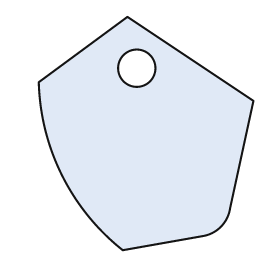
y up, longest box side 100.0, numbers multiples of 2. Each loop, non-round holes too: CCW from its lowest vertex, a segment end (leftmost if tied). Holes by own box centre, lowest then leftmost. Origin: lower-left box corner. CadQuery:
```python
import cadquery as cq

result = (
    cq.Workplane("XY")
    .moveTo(36.0, 0.0)
    .lineTo(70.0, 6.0)
    .threePointArc((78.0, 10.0), (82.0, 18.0))
    .lineTo(92.0, 64.0)
    .lineTo(38.0, 100.0)
    .lineTo(0.0, 72.0)
    .threePointArc((10.0, 32.0), (36.0, 0.0))
    .close()
    .moveTo(42.0, 78.0)
    .circle(8.0)
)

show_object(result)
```